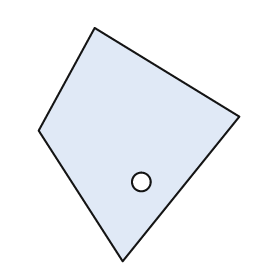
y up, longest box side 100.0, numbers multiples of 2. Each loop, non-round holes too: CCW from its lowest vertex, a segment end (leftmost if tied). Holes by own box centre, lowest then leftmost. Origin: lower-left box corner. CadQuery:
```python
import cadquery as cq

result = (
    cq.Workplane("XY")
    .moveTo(36.0, 0.0)
    .lineTo(86.0, 62.0)
    .lineTo(24.0, 100.0)
    .lineTo(0.0, 56.0)
    .close()
    .moveTo(44.0, 34.0)
    .circle(4.0)
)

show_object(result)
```